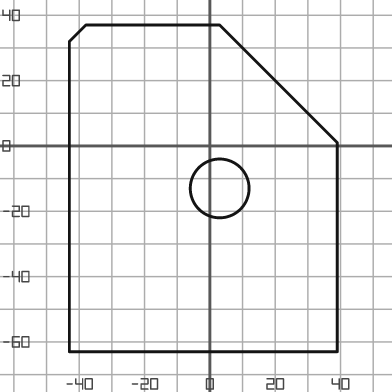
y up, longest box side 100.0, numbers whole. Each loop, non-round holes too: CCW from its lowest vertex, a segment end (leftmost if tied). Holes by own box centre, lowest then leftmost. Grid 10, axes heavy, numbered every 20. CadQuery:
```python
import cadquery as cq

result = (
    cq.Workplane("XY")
    .moveTo(-43.0, -63.0)
    .lineTo(39.0, -63.0)
    .lineTo(39.0, 1.0)
    .lineTo(3.0, 37.0)
    .lineTo(-38.0, 37.0)
    .lineTo(-43.0, 32.0)
    .close()
    .moveTo(3.0, -13.0)
    .circle(9.0)
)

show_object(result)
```